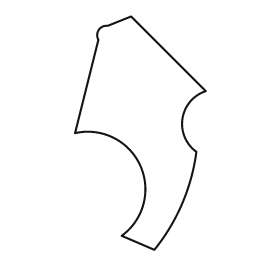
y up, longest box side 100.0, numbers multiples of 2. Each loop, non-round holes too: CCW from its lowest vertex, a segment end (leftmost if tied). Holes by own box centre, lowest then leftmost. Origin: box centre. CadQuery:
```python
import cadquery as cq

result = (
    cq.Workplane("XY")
    .moveTo(6.0, -50.0)
    .threePointArc((18.0, -30.0), (24.0, -8.0))
    .threePointArc((18.0, 6.0), (28.0, 18.0))
    .lineTo(-4.0, 50.0)
    .lineTo(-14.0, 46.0)
    .threePointArc((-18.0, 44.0), (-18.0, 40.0))
    .lineTo(-28.0, 0.0)
    .threePointArc((0.0, -14.0), (-8.0, -44.0))
    .close()
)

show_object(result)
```